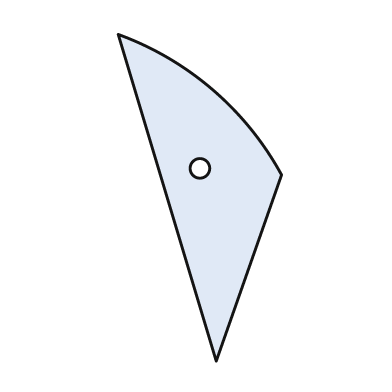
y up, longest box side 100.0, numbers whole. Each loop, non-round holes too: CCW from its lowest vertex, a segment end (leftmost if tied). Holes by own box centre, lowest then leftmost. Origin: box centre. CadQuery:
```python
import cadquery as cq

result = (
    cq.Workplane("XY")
    .moveTo(5.0, -50.0)
    .lineTo(25.0, 7.0)
    .threePointArc((4.0, 33.0), (-25.0, 50.0))
    .close()
    .moveTo(0.0, 9.0)
    .circle(3.0)
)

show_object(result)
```